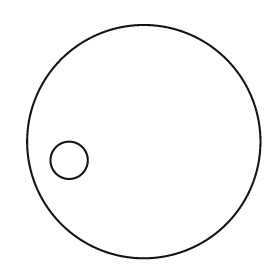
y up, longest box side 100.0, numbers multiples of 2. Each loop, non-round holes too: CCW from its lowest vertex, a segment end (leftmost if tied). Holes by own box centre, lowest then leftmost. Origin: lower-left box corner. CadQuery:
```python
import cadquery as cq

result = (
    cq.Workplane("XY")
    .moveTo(50.0, 50.0)
    .circle(50.0)
    .moveTo(18.0, 42.0)
    .circle(8.0)
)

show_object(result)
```